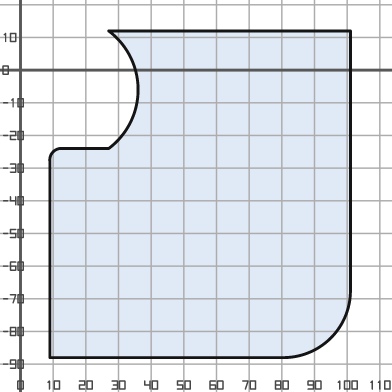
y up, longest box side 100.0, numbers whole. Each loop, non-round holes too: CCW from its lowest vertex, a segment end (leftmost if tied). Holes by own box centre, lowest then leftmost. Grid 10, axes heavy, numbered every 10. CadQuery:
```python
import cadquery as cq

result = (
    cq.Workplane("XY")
    .moveTo(9.0, -88.0)
    .lineTo(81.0, -88.0)
    .threePointArc((95.0, -82.0), (101.0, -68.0))
    .lineTo(101.0, 12.0)
    .lineTo(27.0, 12.0)
    .threePointArc((36.0, -6.0), (27.0, -24.0))
    .lineTo(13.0, -24.0)
    .threePointArc((10.0, -25.0), (9.0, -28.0))
    .close()
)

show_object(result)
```